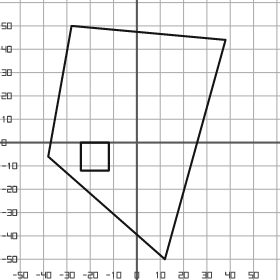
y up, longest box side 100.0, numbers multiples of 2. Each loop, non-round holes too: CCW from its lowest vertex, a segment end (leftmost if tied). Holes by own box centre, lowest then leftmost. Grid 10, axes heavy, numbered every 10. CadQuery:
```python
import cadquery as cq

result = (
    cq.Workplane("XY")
    .moveTo(12.0, -50.0)
    .lineTo(38.0, 44.0)
    .lineTo(-28.0, 50.0)
    .lineTo(-38.0, -6.0)
    .close()
    .moveTo(-24.0, -12.0)
    .lineTo(-12.0, -12.0)
    .lineTo(-12.0, 0.0)
    .lineTo(-24.0, 0.0)
    .close()
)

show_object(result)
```